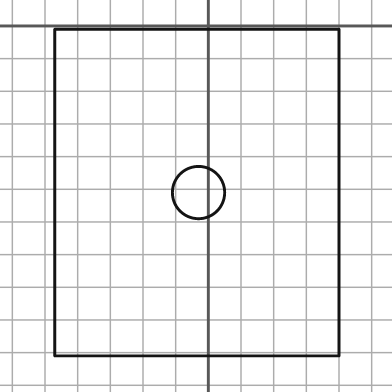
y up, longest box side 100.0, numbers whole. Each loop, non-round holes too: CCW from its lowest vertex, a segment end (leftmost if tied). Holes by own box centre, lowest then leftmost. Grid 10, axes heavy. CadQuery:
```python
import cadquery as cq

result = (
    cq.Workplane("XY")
    .moveTo(-47.0, -101.0)
    .lineTo(40.0, -101.0)
    .lineTo(40.0, -1.0)
    .lineTo(-47.0, -1.0)
    .close()
    .moveTo(-3.0, -51.0)
    .circle(8.0)
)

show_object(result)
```